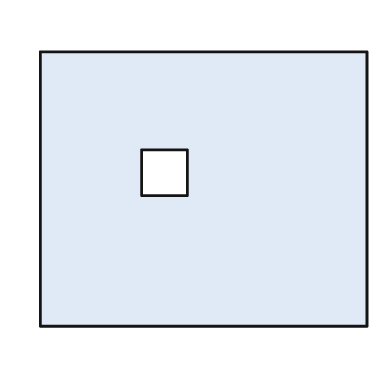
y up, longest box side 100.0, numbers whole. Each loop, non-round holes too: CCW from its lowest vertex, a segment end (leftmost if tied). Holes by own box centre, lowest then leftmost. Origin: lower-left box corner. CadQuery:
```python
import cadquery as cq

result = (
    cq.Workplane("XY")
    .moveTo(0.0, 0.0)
    .lineTo(100.0, 0.0)
    .lineTo(100.0, 84.0)
    .lineTo(0.0, 84.0)
    .close()
    .moveTo(31.0, 40.0)
    .lineTo(45.0, 40.0)
    .lineTo(45.0, 54.0)
    .lineTo(31.0, 54.0)
    .close()
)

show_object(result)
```